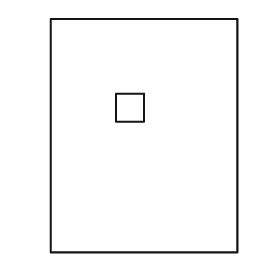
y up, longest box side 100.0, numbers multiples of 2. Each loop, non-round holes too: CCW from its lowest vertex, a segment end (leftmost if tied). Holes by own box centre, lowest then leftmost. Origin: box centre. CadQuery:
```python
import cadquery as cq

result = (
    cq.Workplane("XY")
    .moveTo(-40.0, -50.0)
    .lineTo(40.0, -50.0)
    .lineTo(40.0, 50.0)
    .lineTo(-40.0, 50.0)
    .close()
    .moveTo(-12.0, 6.0)
    .lineTo(0.0, 6.0)
    .lineTo(0.0, 18.0)
    .lineTo(-12.0, 18.0)
    .close()
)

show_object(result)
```